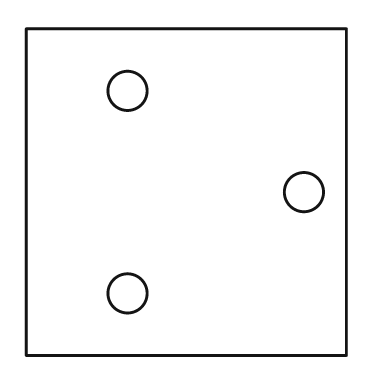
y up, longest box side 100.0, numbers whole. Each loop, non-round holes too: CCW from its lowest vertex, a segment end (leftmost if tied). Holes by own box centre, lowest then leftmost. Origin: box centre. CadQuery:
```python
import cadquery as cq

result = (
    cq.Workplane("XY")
    .moveTo(-49.0, -50.0)
    .lineTo(49.0, -50.0)
    .lineTo(49.0, 50.0)
    .lineTo(-49.0, 50.0)
    .close()
    .moveTo(-18.0, -31.0)
    .circle(6.0)
    .moveTo(36.0, 0.0)
    .circle(6.0)
    .moveTo(-18.0, 31.0)
    .circle(6.0)
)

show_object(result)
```